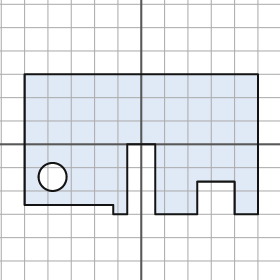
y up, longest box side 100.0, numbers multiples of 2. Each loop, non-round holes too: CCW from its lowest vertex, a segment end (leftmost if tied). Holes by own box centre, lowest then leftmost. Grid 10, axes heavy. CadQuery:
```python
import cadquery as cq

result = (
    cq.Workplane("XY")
    .moveTo(-12.0, -30.0)
    .lineTo(-6.0, -30.0)
    .lineTo(-6.0, 0.0)
    .lineTo(6.0, 0.0)
    .lineTo(6.0, -30.0)
    .lineTo(24.0, -30.0)
    .lineTo(24.0, -16.0)
    .lineTo(40.0, -16.0)
    .lineTo(40.0, -30.0)
    .lineTo(50.0, -30.0)
    .lineTo(50.0, 30.0)
    .lineTo(-50.0, 30.0)
    .lineTo(-50.0, -26.0)
    .lineTo(-12.0, -26.0)
    .close()
    .moveTo(-38.0, -14.0)
    .circle(6.0)
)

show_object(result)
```